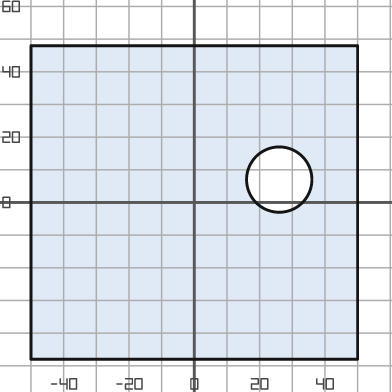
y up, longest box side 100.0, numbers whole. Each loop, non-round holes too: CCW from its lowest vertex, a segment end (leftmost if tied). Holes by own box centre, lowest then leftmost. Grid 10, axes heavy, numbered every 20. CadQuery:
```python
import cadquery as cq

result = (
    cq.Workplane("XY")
    .moveTo(-50.0, -48.0)
    .lineTo(50.0, -48.0)
    .lineTo(50.0, 48.0)
    .lineTo(-50.0, 48.0)
    .close()
    .moveTo(26.0, 7.0)
    .circle(10.0)
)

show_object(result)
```